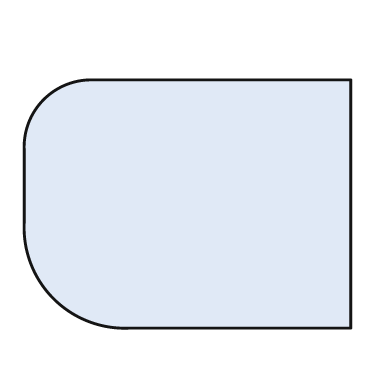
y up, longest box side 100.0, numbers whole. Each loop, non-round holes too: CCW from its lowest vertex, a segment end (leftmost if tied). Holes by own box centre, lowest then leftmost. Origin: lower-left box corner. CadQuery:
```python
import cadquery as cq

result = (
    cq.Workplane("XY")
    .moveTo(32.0, 0.0)
    .lineTo(100.0, 0.0)
    .lineTo(100.0, 76.0)
    .lineTo(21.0, 76.0)
    .threePointArc((6.0, 70.0), (0.0, 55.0))
    .lineTo(0.0, 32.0)
    .threePointArc((9.0, 9.0), (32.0, 0.0))
    .close()
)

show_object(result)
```